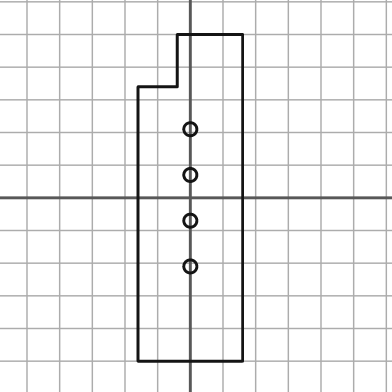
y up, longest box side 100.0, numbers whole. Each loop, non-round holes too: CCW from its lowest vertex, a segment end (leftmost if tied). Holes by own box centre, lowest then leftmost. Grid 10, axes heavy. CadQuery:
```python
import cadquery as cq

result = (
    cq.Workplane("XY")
    .moveTo(-16.0, -50.0)
    .lineTo(16.0, -50.0)
    .lineTo(16.0, 50.0)
    .lineTo(-4.0, 50.0)
    .lineTo(-4.0, 34.0)
    .lineTo(-16.0, 34.0)
    .close()
    .moveTo(0.0, -21.0)
    .circle(2.0)
    .moveTo(0.0, -7.0)
    .circle(2.0)
    .moveTo(0.0, 7.0)
    .circle(2.0)
    .moveTo(0.0, 21.0)
    .circle(2.0)
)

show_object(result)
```